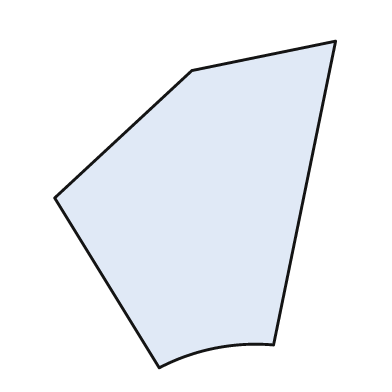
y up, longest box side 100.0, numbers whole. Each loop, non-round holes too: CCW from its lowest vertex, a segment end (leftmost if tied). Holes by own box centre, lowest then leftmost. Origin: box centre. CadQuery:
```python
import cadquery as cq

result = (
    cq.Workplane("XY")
    .moveTo(-11.0, -50.0)
    .threePointArc((6.0, -44.0), (24.0, -43.0))
    .lineTo(43.0, 50.0)
    .lineTo(-1.0, 41.0)
    .lineTo(-43.0, 2.0)
    .close()
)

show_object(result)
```